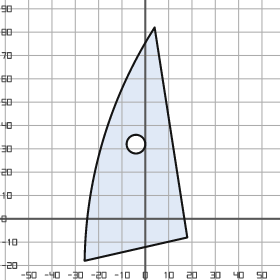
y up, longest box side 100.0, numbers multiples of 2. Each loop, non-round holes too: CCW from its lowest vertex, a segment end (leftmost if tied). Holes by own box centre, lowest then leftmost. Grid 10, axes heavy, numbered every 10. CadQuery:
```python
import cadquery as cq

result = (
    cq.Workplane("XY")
    .moveTo(-26.0, -18.0)
    .lineTo(18.0, -8.0)
    .lineTo(4.0, 82.0)
    .threePointArc((-18.0, 34.0), (-26.0, -18.0))
    .close()
    .moveTo(-4.0, 32.0)
    .circle(4.0)
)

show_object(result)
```